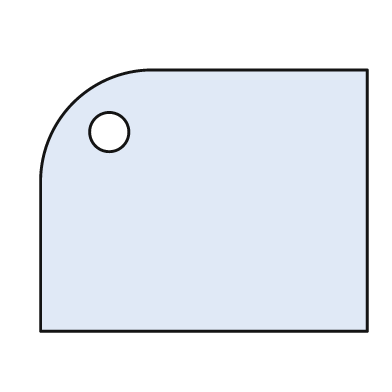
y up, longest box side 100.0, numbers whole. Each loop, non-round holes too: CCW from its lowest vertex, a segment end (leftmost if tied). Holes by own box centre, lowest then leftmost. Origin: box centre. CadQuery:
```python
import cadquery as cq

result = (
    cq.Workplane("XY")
    .moveTo(-50.0, -40.0)
    .lineTo(50.0, -40.0)
    .lineTo(50.0, 40.0)
    .lineTo(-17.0, 40.0)
    .threePointArc((-40.0, 30.0), (-50.0, 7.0))
    .close()
    .moveTo(-29.0, 21.0)
    .circle(6.0)
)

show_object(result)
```